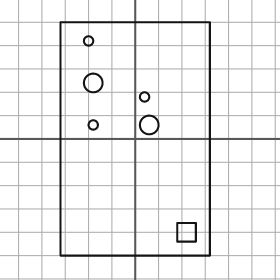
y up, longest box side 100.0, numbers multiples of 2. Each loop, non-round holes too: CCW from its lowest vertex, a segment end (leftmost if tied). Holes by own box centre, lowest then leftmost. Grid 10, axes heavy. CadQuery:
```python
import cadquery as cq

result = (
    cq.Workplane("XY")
    .moveTo(-32.0, -50.0)
    .lineTo(32.0, -50.0)
    .lineTo(32.0, 50.0)
    .lineTo(-32.0, 50.0)
    .close()
    .moveTo(18.0, -44.0)
    .lineTo(26.0, -44.0)
    .lineTo(26.0, -36.0)
    .lineTo(18.0, -36.0)
    .close()
    .moveTo(-18.0, 6.0)
    .circle(2.0)
    .moveTo(6.0, 6.0)
    .circle(4.0)
    .moveTo(4.0, 18.0)
    .circle(2.0)
    .moveTo(-18.0, 24.0)
    .circle(4.0)
    .moveTo(-20.0, 42.0)
    .circle(2.0)
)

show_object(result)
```